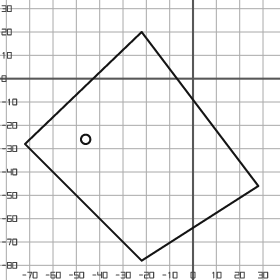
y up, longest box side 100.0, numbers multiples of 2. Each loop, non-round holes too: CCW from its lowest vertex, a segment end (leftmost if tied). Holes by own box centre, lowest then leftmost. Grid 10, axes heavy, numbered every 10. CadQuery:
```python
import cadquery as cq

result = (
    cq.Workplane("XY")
    .moveTo(-22.0, -78.0)
    .lineTo(28.0, -46.0)
    .lineTo(-22.0, 20.0)
    .lineTo(-72.0, -28.0)
    .close()
    .moveTo(-46.0, -26.0)
    .circle(2.0)
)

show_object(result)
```